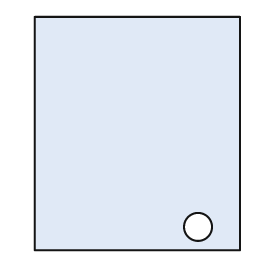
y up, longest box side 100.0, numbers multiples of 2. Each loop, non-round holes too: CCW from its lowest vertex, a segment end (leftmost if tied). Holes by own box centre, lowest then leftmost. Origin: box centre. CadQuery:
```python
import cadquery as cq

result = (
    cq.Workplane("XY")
    .moveTo(-44.0, -50.0)
    .lineTo(44.0, -50.0)
    .lineTo(44.0, 50.0)
    .lineTo(-44.0, 50.0)
    .close()
    .moveTo(26.0, -40.0)
    .circle(6.0)
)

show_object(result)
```